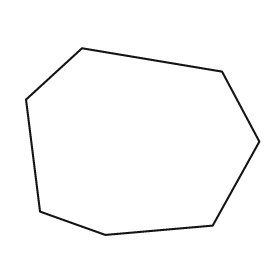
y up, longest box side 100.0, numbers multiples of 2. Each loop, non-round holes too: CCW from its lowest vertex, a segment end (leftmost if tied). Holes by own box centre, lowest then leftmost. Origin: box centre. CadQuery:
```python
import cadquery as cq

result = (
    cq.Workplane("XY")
    .moveTo(-16.0, -40.0)
    .lineTo(30.0, -36.0)
    .lineTo(50.0, 0.0)
    .lineTo(34.0, 30.0)
    .lineTo(-26.0, 40.0)
    .lineTo(-50.0, 18.0)
    .lineTo(-44.0, -30.0)
    .close()
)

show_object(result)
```